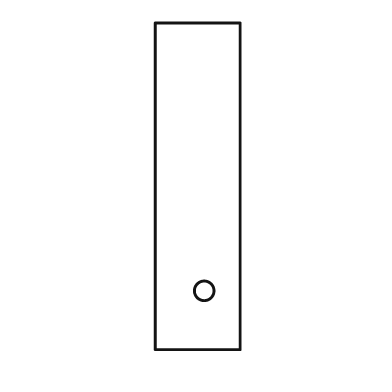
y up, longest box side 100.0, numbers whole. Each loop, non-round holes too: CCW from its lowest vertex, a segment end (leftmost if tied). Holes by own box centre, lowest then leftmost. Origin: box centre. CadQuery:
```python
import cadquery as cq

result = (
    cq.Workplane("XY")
    .moveTo(-13.0, -50.0)
    .lineTo(13.0, -50.0)
    .lineTo(13.0, 50.0)
    .lineTo(-13.0, 50.0)
    .close()
    .moveTo(2.0, -32.0)
    .circle(3.0)
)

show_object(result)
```